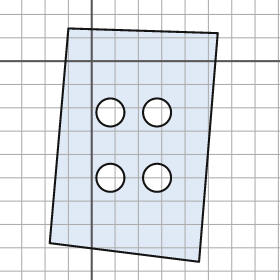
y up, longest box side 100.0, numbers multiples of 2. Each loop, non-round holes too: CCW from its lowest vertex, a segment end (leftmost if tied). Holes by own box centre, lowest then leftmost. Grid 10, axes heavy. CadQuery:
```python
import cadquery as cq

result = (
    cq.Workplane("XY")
    .moveTo(46.0, -86.0)
    .lineTo(54.0, 12.0)
    .lineTo(-10.0, 14.0)
    .lineTo(-18.0, -78.0)
    .close()
    .moveTo(8.0, -50.0)
    .circle(6.0)
    .moveTo(28.0, -50.0)
    .circle(6.0)
    .moveTo(8.0, -22.0)
    .circle(6.0)
    .moveTo(28.0, -22.0)
    .circle(6.0)
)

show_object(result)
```